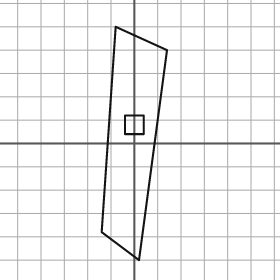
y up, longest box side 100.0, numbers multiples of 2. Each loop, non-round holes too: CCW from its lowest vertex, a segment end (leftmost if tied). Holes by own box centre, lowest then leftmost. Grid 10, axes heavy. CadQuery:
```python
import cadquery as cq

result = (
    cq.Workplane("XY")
    .moveTo(2.0, -50.0)
    .lineTo(14.0, 40.0)
    .lineTo(-8.0, 50.0)
    .lineTo(-14.0, -38.0)
    .close()
    .moveTo(-4.0, 4.0)
    .lineTo(4.0, 4.0)
    .lineTo(4.0, 12.0)
    .lineTo(-4.0, 12.0)
    .close()
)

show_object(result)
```